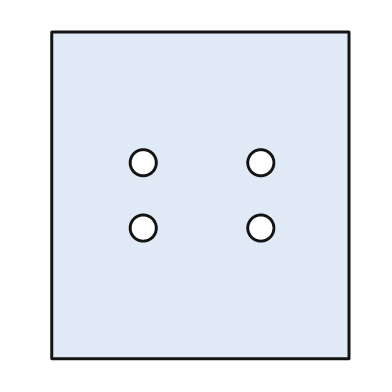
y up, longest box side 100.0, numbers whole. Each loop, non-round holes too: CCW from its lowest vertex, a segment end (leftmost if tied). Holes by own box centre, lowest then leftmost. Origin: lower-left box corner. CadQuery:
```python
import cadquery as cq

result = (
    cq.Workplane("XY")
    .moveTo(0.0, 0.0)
    .lineTo(91.0, 0.0)
    .lineTo(91.0, 100.0)
    .lineTo(0.0, 100.0)
    .close()
    .moveTo(28.0, 40.0)
    .circle(4.0)
    .moveTo(64.0, 40.0)
    .circle(4.0)
    .moveTo(28.0, 60.0)
    .circle(4.0)
    .moveTo(64.0, 60.0)
    .circle(4.0)
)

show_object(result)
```